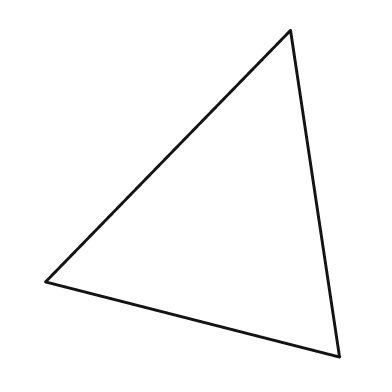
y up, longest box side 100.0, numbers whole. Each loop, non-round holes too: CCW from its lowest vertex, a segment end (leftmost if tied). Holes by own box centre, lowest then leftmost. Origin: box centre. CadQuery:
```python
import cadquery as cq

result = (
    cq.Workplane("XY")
    .moveTo(45.0, -50.0)
    .lineTo(30.0, 50.0)
    .lineTo(-45.0, -27.0)
    .close()
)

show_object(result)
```